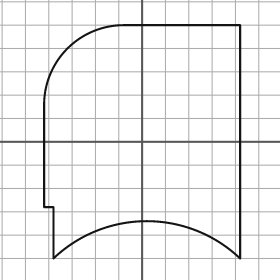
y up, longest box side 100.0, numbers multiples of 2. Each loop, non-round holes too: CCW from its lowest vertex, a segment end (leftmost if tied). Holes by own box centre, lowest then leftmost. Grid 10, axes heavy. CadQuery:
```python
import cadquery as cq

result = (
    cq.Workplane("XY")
    .moveTo(-38.0, -50.0)
    .threePointArc((2.0, -34.0), (42.0, -50.0))
    .lineTo(42.0, 50.0)
    .lineTo(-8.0, 50.0)
    .threePointArc((-32.0, 40.0), (-42.0, 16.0))
    .lineTo(-42.0, -28.0)
    .lineTo(-38.0, -28.0)
    .close()
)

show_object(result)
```